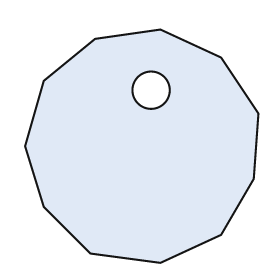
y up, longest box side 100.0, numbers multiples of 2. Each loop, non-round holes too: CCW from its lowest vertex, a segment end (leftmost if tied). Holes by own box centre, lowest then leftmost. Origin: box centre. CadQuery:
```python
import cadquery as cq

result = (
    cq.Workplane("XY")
    .moveTo(8.0, -50.0)
    .lineTo(34.0, -38.0)
    .lineTo(48.0, -14.0)
    .lineTo(50.0, 14.0)
    .lineTo(34.0, 38.0)
    .lineTo(8.0, 50.0)
    .lineTo(-20.0, 46.0)
    .lineTo(-42.0, 28.0)
    .lineTo(-50.0, 0.0)
    .lineTo(-42.0, -26.0)
    .lineTo(-22.0, -46.0)
    .close()
    .moveTo(4.0, 24.0)
    .circle(8.0)
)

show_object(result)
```